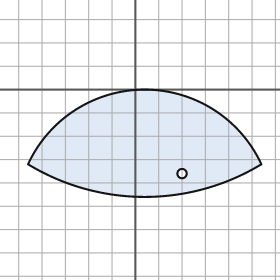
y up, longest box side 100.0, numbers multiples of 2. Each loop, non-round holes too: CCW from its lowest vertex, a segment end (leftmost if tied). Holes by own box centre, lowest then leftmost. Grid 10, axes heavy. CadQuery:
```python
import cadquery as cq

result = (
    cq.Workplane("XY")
    .moveTo(-46.0, -32.0)
    .threePointArc((4.0, -46.0), (54.0, -32.0))
    .threePointArc((4.0, 0.0), (-46.0, -32.0))
    .close()
    .moveTo(20.0, -36.0)
    .circle(2.0)
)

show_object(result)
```